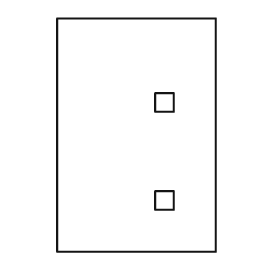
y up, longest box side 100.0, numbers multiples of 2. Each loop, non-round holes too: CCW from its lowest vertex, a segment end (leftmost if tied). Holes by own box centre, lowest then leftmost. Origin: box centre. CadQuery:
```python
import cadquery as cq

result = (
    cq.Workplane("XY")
    .moveTo(-34.0, -50.0)
    .lineTo(34.0, -50.0)
    .lineTo(34.0, 50.0)
    .lineTo(-34.0, 50.0)
    .close()
    .moveTo(8.0, -32.0)
    .lineTo(16.0, -32.0)
    .lineTo(16.0, -24.0)
    .lineTo(8.0, -24.0)
    .close()
    .moveTo(8.0, 10.0)
    .lineTo(16.0, 10.0)
    .lineTo(16.0, 18.0)
    .lineTo(8.0, 18.0)
    .close()
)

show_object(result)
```